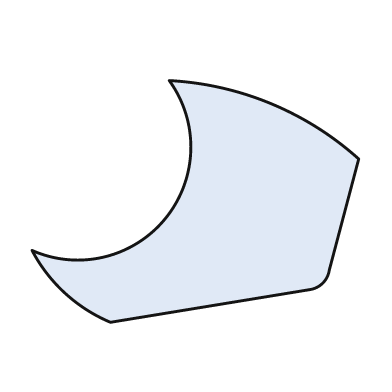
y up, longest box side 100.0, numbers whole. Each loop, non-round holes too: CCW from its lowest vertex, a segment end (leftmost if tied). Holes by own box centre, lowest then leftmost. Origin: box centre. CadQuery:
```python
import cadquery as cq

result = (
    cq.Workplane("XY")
    .moveTo(-26.0, -37.0)
    .lineTo(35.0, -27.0)
    .threePointArc((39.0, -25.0), (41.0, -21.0))
    .lineTo(50.0, 13.0)
    .threePointArc((23.0, 30.0), (-8.0, 37.0))
    .threePointArc((-9.0, -5.0), (-50.0, -15.0))
    .threePointArc((-40.0, -28.0), (-26.0, -37.0))
    .close()
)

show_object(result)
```